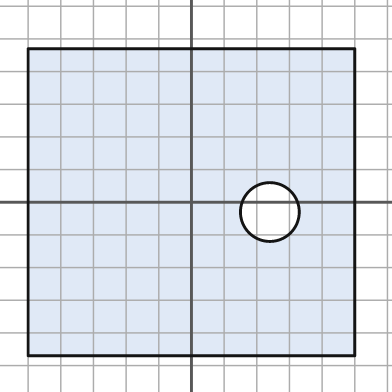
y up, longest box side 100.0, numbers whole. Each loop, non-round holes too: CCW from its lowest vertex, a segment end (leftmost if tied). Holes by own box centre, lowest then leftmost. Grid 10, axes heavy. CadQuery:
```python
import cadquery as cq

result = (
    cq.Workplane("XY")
    .moveTo(-50.0, -47.0)
    .lineTo(50.0, -47.0)
    .lineTo(50.0, 47.0)
    .lineTo(-50.0, 47.0)
    .close()
    .moveTo(24.0, -3.0)
    .circle(9.0)
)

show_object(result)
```